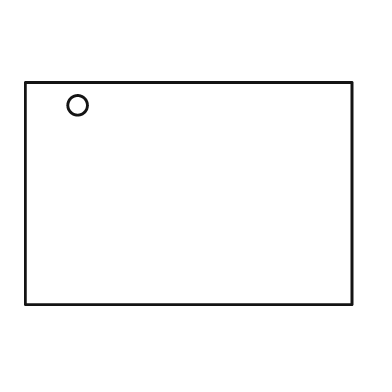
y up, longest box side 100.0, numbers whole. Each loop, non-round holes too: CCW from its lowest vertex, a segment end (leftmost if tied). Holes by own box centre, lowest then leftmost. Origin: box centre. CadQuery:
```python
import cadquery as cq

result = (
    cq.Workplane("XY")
    .moveTo(-50.0, -34.0)
    .lineTo(50.0, -34.0)
    .lineTo(50.0, 34.0)
    .lineTo(-50.0, 34.0)
    .close()
    .moveTo(-34.0, 27.0)
    .circle(3.0)
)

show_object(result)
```